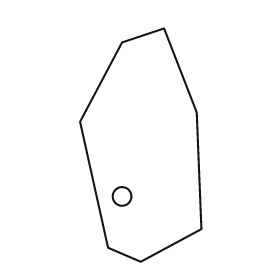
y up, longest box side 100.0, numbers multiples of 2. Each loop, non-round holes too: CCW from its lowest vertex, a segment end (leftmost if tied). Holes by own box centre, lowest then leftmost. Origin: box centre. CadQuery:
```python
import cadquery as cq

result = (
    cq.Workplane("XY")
    .moveTo(0.0, -50.0)
    .lineTo(26.0, -36.0)
    .lineTo(24.0, 14.0)
    .lineTo(10.0, 50.0)
    .lineTo(-8.0, 44.0)
    .lineTo(-26.0, 10.0)
    .lineTo(-14.0, -44.0)
    .close()
    .moveTo(-8.0, -22.0)
    .circle(4.0)
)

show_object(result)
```